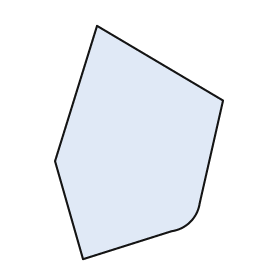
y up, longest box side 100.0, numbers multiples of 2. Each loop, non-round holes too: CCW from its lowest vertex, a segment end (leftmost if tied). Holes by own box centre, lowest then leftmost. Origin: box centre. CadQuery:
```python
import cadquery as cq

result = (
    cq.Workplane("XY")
    .moveTo(-24.0, -50.0)
    .lineTo(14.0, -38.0)
    .threePointArc((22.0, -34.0), (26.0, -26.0))
    .lineTo(36.0, 18.0)
    .lineTo(-18.0, 50.0)
    .lineTo(-36.0, -8.0)
    .close()
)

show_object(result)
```